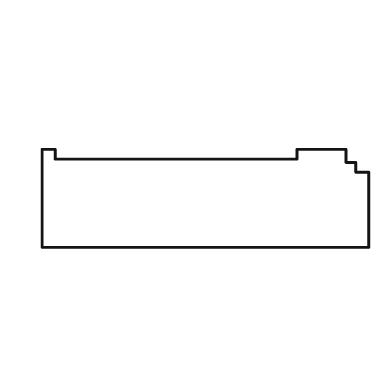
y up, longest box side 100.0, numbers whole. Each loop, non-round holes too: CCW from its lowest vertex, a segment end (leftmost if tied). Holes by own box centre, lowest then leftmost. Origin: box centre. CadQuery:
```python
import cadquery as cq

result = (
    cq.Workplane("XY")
    .moveTo(-50.0, -15.0)
    .lineTo(50.0, -15.0)
    .lineTo(50.0, 8.0)
    .lineTo(46.0, 8.0)
    .lineTo(46.0, 11.0)
    .lineTo(43.0, 11.0)
    .lineTo(43.0, 15.0)
    .lineTo(28.0, 15.0)
    .lineTo(28.0, 12.0)
    .lineTo(-46.0, 12.0)
    .lineTo(-46.0, 15.0)
    .lineTo(-50.0, 15.0)
    .close()
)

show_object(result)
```